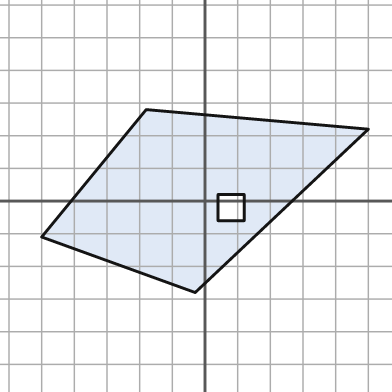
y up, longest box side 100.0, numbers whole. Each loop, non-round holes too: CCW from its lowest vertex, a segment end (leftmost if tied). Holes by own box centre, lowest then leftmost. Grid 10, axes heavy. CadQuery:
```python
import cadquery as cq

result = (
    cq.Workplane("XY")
    .moveTo(-3.0, -28.0)
    .lineTo(50.0, 22.0)
    .lineTo(-18.0, 28.0)
    .lineTo(-50.0, -11.0)
    .close()
    .moveTo(4.0, -6.0)
    .lineTo(12.0, -6.0)
    .lineTo(12.0, 2.0)
    .lineTo(4.0, 2.0)
    .close()
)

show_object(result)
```